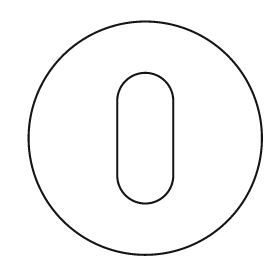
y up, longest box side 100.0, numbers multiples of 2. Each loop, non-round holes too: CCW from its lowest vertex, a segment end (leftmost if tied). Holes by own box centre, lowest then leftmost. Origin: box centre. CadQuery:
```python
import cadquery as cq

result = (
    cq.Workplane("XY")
    .moveTo(0.0, 0.0)
    .circle(50.0)
    .moveTo(-12.0, -16.0)
    .threePointArc((0.0, -28.0), (12.0, -16.0))
    .lineTo(12.0, 16.0)
    .threePointArc((0.0, 28.0), (-12.0, 16.0))
    .close()
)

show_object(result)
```